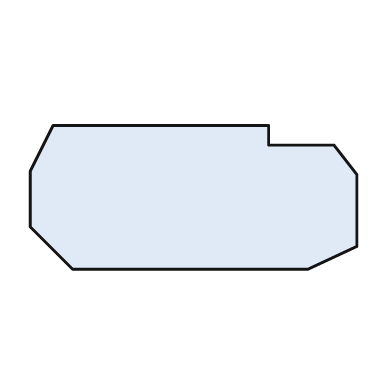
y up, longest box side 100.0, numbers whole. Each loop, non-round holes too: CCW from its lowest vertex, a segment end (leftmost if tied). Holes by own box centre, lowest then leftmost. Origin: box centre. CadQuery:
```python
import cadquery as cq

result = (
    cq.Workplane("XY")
    .moveTo(-37.0, -22.0)
    .lineTo(35.0, -22.0)
    .lineTo(50.0, -15.0)
    .lineTo(50.0, 7.0)
    .lineTo(43.0, 16.0)
    .lineTo(23.0, 16.0)
    .lineTo(23.0, 22.0)
    .lineTo(-43.0, 22.0)
    .lineTo(-50.0, 8.0)
    .lineTo(-50.0, -9.0)
    .close()
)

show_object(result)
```